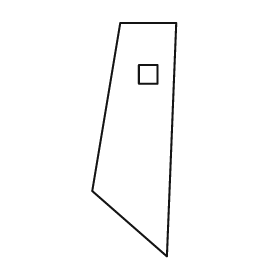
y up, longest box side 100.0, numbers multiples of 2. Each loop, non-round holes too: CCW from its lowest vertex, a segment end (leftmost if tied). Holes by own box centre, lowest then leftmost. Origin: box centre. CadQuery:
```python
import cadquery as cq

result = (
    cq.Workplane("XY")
    .moveTo(14.0, -50.0)
    .lineTo(18.0, 50.0)
    .lineTo(-6.0, 50.0)
    .lineTo(-18.0, -22.0)
    .close()
    .moveTo(2.0, 24.0)
    .lineTo(10.0, 24.0)
    .lineTo(10.0, 32.0)
    .lineTo(2.0, 32.0)
    .close()
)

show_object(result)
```